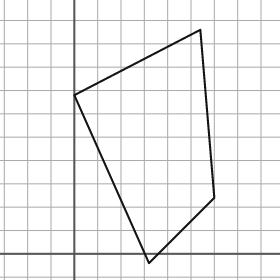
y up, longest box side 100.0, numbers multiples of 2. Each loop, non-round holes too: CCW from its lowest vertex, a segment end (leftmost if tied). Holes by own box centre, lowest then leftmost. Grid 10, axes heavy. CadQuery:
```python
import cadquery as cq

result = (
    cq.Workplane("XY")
    .moveTo(32.0, -4.0)
    .lineTo(60.0, 24.0)
    .lineTo(54.0, 96.0)
    .lineTo(0.0, 68.0)
    .close()
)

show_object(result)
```